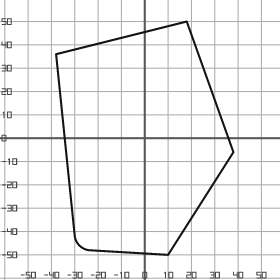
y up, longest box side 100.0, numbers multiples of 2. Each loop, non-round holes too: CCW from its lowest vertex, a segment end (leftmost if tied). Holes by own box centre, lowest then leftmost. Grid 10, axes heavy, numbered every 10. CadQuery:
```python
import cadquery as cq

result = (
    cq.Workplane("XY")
    .moveTo(10.0, -50.0)
    .lineTo(38.0, -6.0)
    .lineTo(18.0, 50.0)
    .lineTo(-38.0, 36.0)
    .lineTo(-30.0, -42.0)
    .threePointArc((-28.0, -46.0), (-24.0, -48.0))
    .close()
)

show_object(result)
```